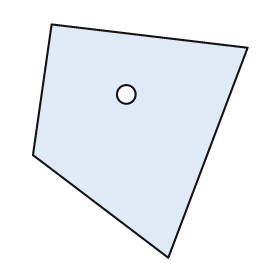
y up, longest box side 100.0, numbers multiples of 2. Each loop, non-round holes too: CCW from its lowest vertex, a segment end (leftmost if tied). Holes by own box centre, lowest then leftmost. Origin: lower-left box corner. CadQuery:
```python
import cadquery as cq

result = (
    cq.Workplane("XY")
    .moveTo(58.0, 0.0)
    .lineTo(92.0, 90.0)
    .lineTo(8.0, 100.0)
    .lineTo(0.0, 44.0)
    .close()
    .moveTo(40.0, 70.0)
    .circle(4.0)
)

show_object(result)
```